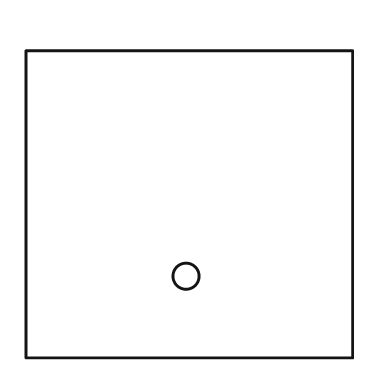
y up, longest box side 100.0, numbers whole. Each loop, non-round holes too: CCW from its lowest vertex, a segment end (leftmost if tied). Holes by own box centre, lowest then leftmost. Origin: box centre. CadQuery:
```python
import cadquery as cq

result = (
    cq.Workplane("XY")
    .moveTo(-50.0, -47.0)
    .lineTo(50.0, -47.0)
    .lineTo(50.0, 47.0)
    .lineTo(-50.0, 47.0)
    .close()
    .moveTo(-1.0, -22.0)
    .circle(4.0)
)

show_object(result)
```